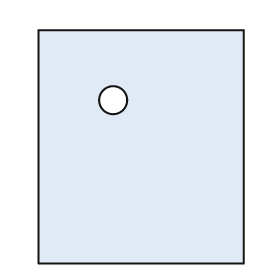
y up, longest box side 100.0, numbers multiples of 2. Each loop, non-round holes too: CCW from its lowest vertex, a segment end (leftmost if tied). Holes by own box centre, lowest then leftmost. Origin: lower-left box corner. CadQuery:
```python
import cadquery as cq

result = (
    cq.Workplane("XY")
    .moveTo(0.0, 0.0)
    .lineTo(88.0, 0.0)
    .lineTo(88.0, 100.0)
    .lineTo(0.0, 100.0)
    .close()
    .moveTo(32.0, 70.0)
    .circle(6.0)
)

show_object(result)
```